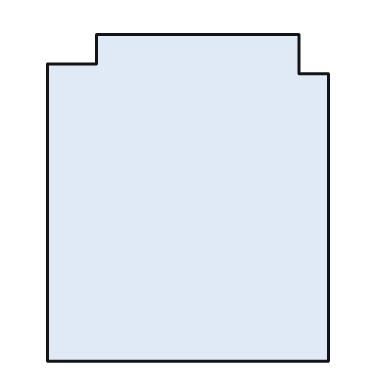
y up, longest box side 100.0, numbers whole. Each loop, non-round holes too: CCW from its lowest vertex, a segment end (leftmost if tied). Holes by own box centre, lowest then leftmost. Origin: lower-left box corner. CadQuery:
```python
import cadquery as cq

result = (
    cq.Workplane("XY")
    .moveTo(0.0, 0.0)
    .lineTo(86.0, 0.0)
    .lineTo(86.0, 88.0)
    .lineTo(77.0, 88.0)
    .lineTo(77.0, 100.0)
    .lineTo(15.0, 100.0)
    .lineTo(15.0, 91.0)
    .lineTo(0.0, 91.0)
    .close()
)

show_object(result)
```